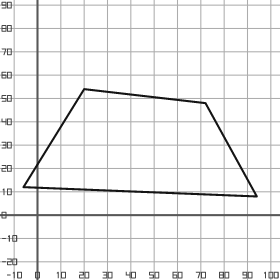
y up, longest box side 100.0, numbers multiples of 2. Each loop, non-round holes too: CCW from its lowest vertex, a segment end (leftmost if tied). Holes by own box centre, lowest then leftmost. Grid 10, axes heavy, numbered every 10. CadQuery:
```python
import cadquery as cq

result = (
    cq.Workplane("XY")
    .moveTo(94.0, 8.0)
    .lineTo(72.0, 48.0)
    .lineTo(20.0, 54.0)
    .lineTo(-6.0, 12.0)
    .close()
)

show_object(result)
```